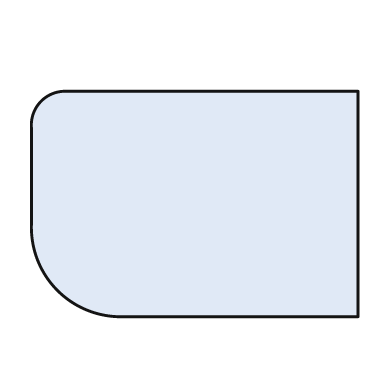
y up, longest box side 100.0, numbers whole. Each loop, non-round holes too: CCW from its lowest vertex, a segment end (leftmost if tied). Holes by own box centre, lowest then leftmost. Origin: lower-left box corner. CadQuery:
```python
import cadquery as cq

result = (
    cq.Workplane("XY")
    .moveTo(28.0, 0.0)
    .lineTo(100.0, 0.0)
    .lineTo(100.0, 69.0)
    .lineTo(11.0, 69.0)
    .threePointArc((3.0, 66.0), (0.0, 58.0))
    .lineTo(0.0, 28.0)
    .threePointArc((8.0, 8.0), (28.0, 0.0))
    .close()
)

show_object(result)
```